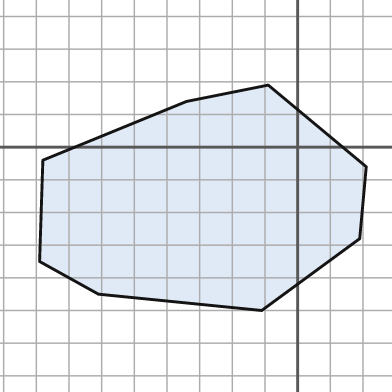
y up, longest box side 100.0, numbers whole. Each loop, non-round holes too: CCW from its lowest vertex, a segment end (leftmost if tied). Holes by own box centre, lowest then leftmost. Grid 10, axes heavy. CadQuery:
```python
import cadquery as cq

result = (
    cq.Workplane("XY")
    .moveTo(-11.0, -50.0)
    .lineTo(19.0, -28.0)
    .lineTo(21.0, -6.0)
    .lineTo(-9.0, 19.0)
    .lineTo(-34.0, 14.0)
    .lineTo(-78.0, -4.0)
    .lineTo(-79.0, -35.0)
    .lineTo(-61.0, -45.0)
    .close()
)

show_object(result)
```